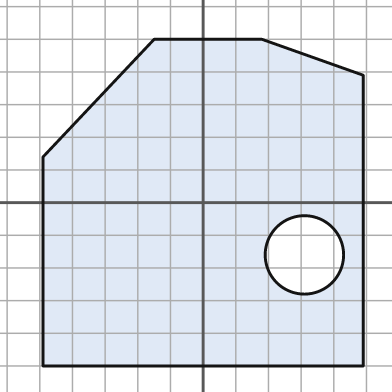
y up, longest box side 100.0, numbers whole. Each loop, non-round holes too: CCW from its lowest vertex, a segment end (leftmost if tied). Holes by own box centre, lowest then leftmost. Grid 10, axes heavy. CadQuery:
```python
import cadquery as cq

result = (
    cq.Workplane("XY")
    .moveTo(-49.0, -50.0)
    .lineTo(49.0, -50.0)
    .lineTo(49.0, 39.0)
    .lineTo(18.0, 50.0)
    .lineTo(-15.0, 50.0)
    .lineTo(-49.0, 14.0)
    .close()
    .moveTo(31.0, -16.0)
    .circle(12.0)
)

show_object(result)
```